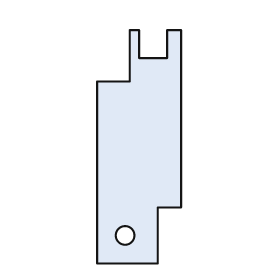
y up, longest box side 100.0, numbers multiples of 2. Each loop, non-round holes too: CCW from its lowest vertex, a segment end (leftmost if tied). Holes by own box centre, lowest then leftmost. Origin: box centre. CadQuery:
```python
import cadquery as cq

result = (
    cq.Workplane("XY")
    .moveTo(-18.0, -50.0)
    .lineTo(8.0, -50.0)
    .lineTo(8.0, -26.0)
    .lineTo(18.0, -26.0)
    .lineTo(18.0, 50.0)
    .lineTo(12.0, 50.0)
    .lineTo(12.0, 38.0)
    .lineTo(0.0, 38.0)
    .lineTo(0.0, 50.0)
    .lineTo(-4.0, 50.0)
    .lineTo(-4.0, 28.0)
    .lineTo(-18.0, 28.0)
    .close()
    .moveTo(-6.0, -38.0)
    .circle(4.0)
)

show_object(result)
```